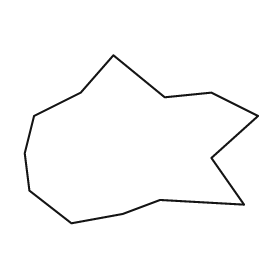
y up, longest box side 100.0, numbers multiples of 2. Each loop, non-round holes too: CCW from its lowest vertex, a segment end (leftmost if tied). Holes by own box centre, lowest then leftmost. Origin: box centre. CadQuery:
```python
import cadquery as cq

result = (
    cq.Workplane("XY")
    .moveTo(-30.0, -36.0)
    .lineTo(-8.0, -32.0)
    .lineTo(8.0, -26.0)
    .lineTo(44.0, -28.0)
    .lineTo(30.0, -8.0)
    .lineTo(50.0, 10.0)
    .lineTo(30.0, 20.0)
    .lineTo(10.0, 18.0)
    .lineTo(-12.0, 36.0)
    .lineTo(-26.0, 20.0)
    .lineTo(-46.0, 10.0)
    .lineTo(-50.0, -6.0)
    .lineTo(-48.0, -22.0)
    .close()
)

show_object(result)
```